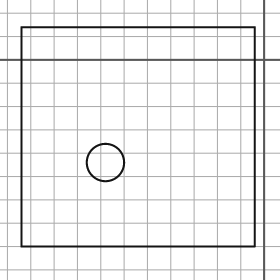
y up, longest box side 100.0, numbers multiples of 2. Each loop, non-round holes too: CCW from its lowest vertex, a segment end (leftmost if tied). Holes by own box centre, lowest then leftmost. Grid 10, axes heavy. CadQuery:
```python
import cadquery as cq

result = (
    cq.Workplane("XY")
    .moveTo(-104.0, -80.0)
    .lineTo(-4.0, -80.0)
    .lineTo(-4.0, 14.0)
    .lineTo(-104.0, 14.0)
    .close()
    .moveTo(-68.0, -44.0)
    .circle(8.0)
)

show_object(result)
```